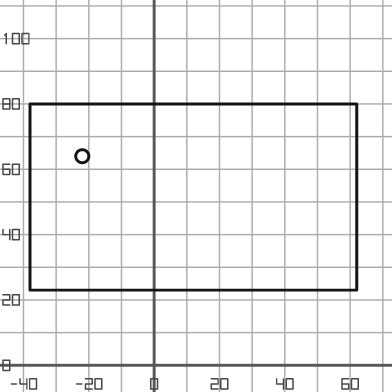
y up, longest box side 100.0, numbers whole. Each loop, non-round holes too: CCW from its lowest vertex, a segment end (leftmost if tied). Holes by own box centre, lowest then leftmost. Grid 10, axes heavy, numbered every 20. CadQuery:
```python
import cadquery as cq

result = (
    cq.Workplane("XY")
    .moveTo(-38.0, 23.0)
    .lineTo(62.0, 23.0)
    .lineTo(62.0, 80.0)
    .lineTo(-38.0, 80.0)
    .close()
    .moveTo(-22.0, 64.0)
    .circle(2.0)
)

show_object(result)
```